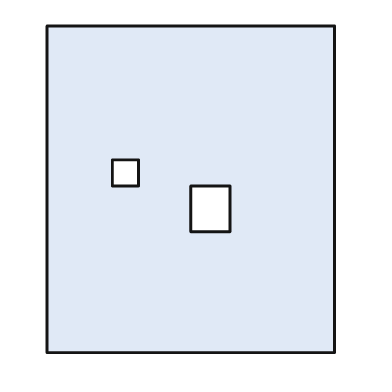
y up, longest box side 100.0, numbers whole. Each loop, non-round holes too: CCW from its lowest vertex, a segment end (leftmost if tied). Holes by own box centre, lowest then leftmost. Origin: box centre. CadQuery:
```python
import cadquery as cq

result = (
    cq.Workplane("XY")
    .moveTo(-44.0, -50.0)
    .lineTo(44.0, -50.0)
    .lineTo(44.0, 50.0)
    .lineTo(-44.0, 50.0)
    .close()
    .moveTo(0.0, -13.0)
    .lineTo(12.0, -13.0)
    .lineTo(12.0, 1.0)
    .lineTo(0.0, 1.0)
    .close()
    .moveTo(-24.0, 1.0)
    .lineTo(-16.0, 1.0)
    .lineTo(-16.0, 9.0)
    .lineTo(-24.0, 9.0)
    .close()
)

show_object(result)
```